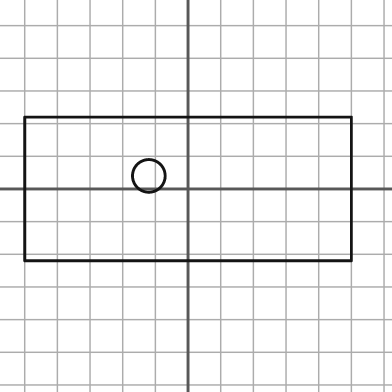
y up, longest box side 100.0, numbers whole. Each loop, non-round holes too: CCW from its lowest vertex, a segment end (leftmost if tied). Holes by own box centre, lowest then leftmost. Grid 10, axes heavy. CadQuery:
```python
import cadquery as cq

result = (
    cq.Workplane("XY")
    .moveTo(-50.0, -22.0)
    .lineTo(50.0, -22.0)
    .lineTo(50.0, 22.0)
    .lineTo(-50.0, 22.0)
    .close()
    .moveTo(-12.0, 4.0)
    .circle(5.0)
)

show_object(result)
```